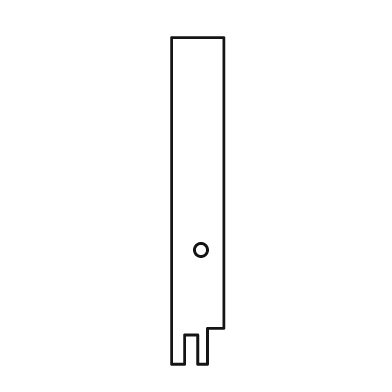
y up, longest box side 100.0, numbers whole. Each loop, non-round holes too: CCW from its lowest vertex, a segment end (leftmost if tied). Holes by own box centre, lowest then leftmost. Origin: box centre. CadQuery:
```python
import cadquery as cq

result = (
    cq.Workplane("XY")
    .moveTo(-8.0, -50.0)
    .lineTo(-4.0, -50.0)
    .lineTo(-4.0, -41.0)
    .lineTo(0.0, -41.0)
    .lineTo(0.0, -50.0)
    .lineTo(3.0, -50.0)
    .lineTo(3.0, -39.0)
    .lineTo(8.0, -39.0)
    .lineTo(8.0, 50.0)
    .lineTo(-8.0, 50.0)
    .close()
    .moveTo(1.0, -15.0)
    .circle(2.0)
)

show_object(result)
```